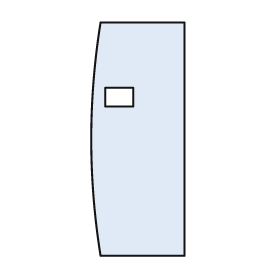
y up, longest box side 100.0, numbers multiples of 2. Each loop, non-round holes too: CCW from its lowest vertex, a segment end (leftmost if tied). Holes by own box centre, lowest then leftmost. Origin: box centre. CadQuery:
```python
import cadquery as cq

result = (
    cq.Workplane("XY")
    .moveTo(-16.0, -50.0)
    .lineTo(20.0, -50.0)
    .lineTo(20.0, 50.0)
    .lineTo(-16.0, 50.0)
    .threePointArc((-20.0, 0.0), (-16.0, -50.0))
    .close()
    .moveTo(-14.0, 14.0)
    .lineTo(-2.0, 14.0)
    .lineTo(-2.0, 22.0)
    .lineTo(-14.0, 22.0)
    .close()
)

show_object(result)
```